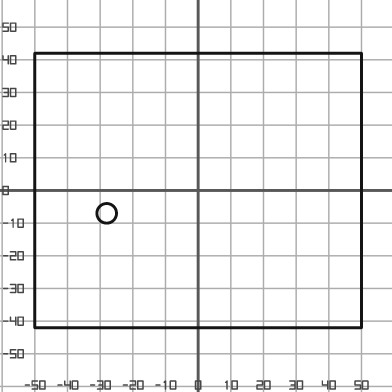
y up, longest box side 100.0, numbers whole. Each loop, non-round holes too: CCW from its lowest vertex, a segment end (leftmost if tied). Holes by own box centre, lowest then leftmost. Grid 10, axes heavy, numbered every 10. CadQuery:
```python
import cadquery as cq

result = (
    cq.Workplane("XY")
    .moveTo(-50.0, -42.0)
    .lineTo(50.0, -42.0)
    .lineTo(50.0, 42.0)
    .lineTo(-50.0, 42.0)
    .close()
    .moveTo(-28.0, -7.0)
    .circle(3.0)
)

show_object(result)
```